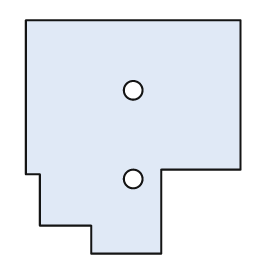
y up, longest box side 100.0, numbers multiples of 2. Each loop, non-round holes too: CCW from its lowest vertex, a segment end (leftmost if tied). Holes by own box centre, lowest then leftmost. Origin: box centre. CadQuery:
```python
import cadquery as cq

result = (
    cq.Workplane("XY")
    .moveTo(-18.0, -50.0)
    .lineTo(12.0, -50.0)
    .lineTo(12.0, -14.0)
    .lineTo(46.0, -14.0)
    .lineTo(46.0, 50.0)
    .lineTo(-46.0, 50.0)
    .lineTo(-46.0, -16.0)
    .lineTo(-40.0, -16.0)
    .lineTo(-40.0, -38.0)
    .lineTo(-18.0, -38.0)
    .close()
    .moveTo(0.0, -18.0)
    .circle(4.0)
    .moveTo(0.0, 20.0)
    .circle(4.0)
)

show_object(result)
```